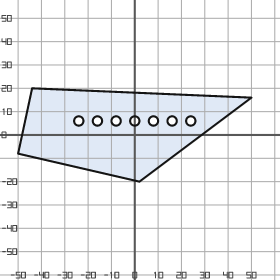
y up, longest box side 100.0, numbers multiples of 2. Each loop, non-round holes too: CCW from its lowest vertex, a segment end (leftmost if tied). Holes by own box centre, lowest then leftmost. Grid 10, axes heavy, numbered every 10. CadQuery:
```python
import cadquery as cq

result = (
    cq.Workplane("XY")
    .moveTo(2.0, -20.0)
    .lineTo(50.0, 16.0)
    .lineTo(-44.0, 20.0)
    .lineTo(-50.0, -8.0)
    .close()
    .moveTo(-24.0, 6.0)
    .circle(2.0)
    .moveTo(-16.0, 6.0)
    .circle(2.0)
    .moveTo(-8.0, 6.0)
    .circle(2.0)
    .moveTo(0.0, 6.0)
    .circle(2.0)
    .moveTo(8.0, 6.0)
    .circle(2.0)
    .moveTo(16.0, 6.0)
    .circle(2.0)
    .moveTo(24.0, 6.0)
    .circle(2.0)
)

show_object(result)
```